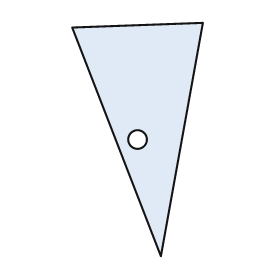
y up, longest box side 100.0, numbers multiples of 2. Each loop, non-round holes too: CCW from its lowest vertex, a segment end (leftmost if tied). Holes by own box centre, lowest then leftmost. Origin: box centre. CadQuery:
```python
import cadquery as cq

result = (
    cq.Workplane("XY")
    .moveTo(10.0, -50.0)
    .lineTo(28.0, 50.0)
    .lineTo(-28.0, 48.0)
    .close()
    .moveTo(0.0, 0.0)
    .circle(4.0)
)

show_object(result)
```